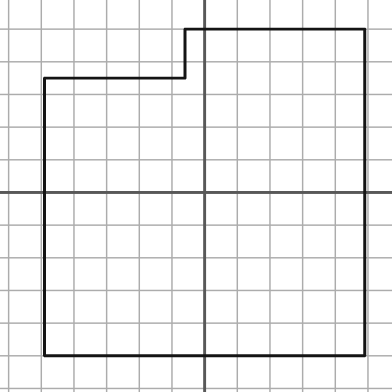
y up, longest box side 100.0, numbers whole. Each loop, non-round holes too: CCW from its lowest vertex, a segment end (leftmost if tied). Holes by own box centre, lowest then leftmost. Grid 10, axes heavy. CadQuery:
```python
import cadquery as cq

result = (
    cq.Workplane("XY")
    .moveTo(-49.0, -50.0)
    .lineTo(49.0, -50.0)
    .lineTo(49.0, 50.0)
    .lineTo(-6.0, 50.0)
    .lineTo(-6.0, 35.0)
    .lineTo(-49.0, 35.0)
    .close()
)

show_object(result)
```